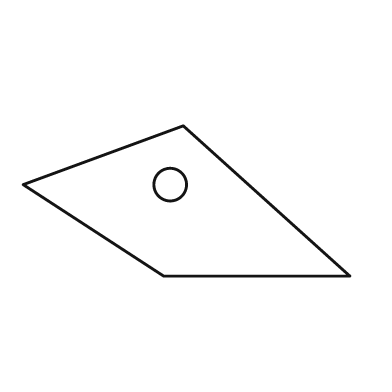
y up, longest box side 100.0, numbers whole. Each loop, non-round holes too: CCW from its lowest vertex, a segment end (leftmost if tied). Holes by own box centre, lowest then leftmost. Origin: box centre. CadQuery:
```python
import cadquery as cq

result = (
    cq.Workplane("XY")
    .moveTo(-7.0, -23.0)
    .lineTo(50.0, -23.0)
    .lineTo(-1.0, 23.0)
    .lineTo(-50.0, 5.0)
    .close()
    .moveTo(-5.0, 5.0)
    .circle(5.0)
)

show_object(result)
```